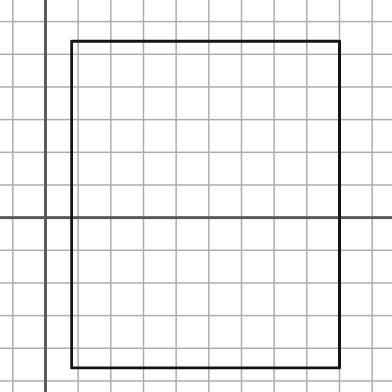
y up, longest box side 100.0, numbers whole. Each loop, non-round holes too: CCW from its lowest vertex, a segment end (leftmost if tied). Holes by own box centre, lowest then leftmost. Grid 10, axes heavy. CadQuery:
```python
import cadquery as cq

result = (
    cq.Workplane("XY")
    .moveTo(8.0, -46.0)
    .lineTo(90.0, -46.0)
    .lineTo(90.0, 54.0)
    .lineTo(8.0, 54.0)
    .close()
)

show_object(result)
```